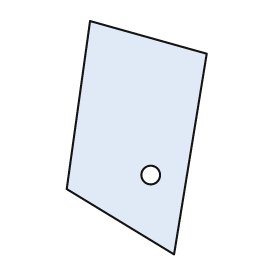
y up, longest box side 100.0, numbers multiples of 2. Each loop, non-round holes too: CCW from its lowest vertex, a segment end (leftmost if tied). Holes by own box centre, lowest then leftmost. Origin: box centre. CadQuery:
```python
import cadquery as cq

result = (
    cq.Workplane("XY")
    .moveTo(16.0, -50.0)
    .lineTo(30.0, 36.0)
    .lineTo(-20.0, 50.0)
    .lineTo(-30.0, -22.0)
    .close()
    .moveTo(6.0, -16.0)
    .circle(4.0)
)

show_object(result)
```